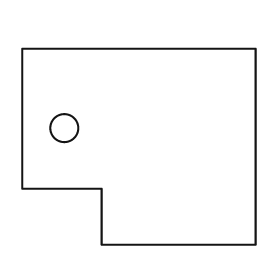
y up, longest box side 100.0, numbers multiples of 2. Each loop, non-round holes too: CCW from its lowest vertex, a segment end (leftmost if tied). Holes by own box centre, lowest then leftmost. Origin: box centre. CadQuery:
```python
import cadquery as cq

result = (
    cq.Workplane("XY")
    .moveTo(-16.0, -42.0)
    .lineTo(50.0, -42.0)
    .lineTo(50.0, 42.0)
    .lineTo(-50.0, 42.0)
    .lineTo(-50.0, -18.0)
    .lineTo(-16.0, -18.0)
    .close()
    .moveTo(-32.0, 8.0)
    .circle(6.0)
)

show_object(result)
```